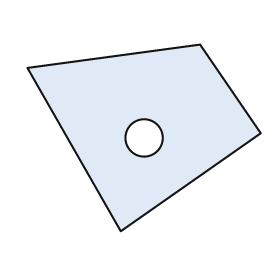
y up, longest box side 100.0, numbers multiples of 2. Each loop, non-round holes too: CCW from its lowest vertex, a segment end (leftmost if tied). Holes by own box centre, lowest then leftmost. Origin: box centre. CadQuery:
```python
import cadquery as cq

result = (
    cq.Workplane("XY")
    .moveTo(-10.0, -40.0)
    .lineTo(50.0, 2.0)
    .lineTo(24.0, 40.0)
    .lineTo(-50.0, 30.0)
    .close()
    .moveTo(0.0, 0.0)
    .circle(8.0)
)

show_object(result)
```